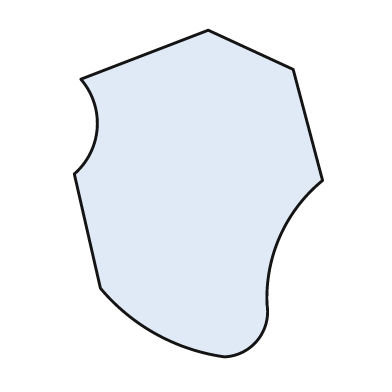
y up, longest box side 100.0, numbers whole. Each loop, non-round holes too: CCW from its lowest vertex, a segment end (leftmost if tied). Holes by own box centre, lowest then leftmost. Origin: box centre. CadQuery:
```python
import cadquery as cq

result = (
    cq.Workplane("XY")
    .moveTo(8.0, -50.0)
    .threePointArc((18.0, -45.0), (21.0, -34.0))
    .threePointArc((25.0, -13.0), (38.0, 4.0))
    .lineTo(29.0, 38.0)
    .lineTo(3.0, 50.0)
    .lineTo(-36.0, 35.0)
    .threePointArc((-31.0, 20.0), (-38.0, 6.0))
    .lineTo(-30.0, -29.0)
    .threePointArc((-13.0, -43.0), (8.0, -50.0))
    .close()
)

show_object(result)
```